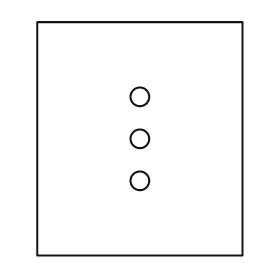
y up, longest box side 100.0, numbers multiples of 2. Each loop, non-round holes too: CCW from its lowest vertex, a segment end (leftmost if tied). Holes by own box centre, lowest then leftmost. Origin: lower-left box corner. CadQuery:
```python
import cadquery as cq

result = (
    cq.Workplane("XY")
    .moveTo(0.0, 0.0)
    .lineTo(88.0, 0.0)
    .lineTo(88.0, 100.0)
    .lineTo(0.0, 100.0)
    .close()
    .moveTo(44.0, 32.0)
    .circle(4.0)
    .moveTo(44.0, 50.0)
    .circle(4.0)
    .moveTo(44.0, 68.0)
    .circle(4.0)
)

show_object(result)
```